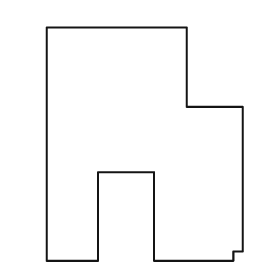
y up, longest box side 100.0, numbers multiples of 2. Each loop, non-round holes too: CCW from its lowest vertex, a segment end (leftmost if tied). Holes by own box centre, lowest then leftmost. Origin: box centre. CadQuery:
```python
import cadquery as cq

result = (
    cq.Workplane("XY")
    .moveTo(-42.0, -50.0)
    .lineTo(-20.0, -50.0)
    .lineTo(-20.0, -12.0)
    .lineTo(4.0, -12.0)
    .lineTo(4.0, -50.0)
    .lineTo(38.0, -50.0)
    .lineTo(38.0, -46.0)
    .lineTo(42.0, -46.0)
    .lineTo(42.0, 16.0)
    .lineTo(18.0, 16.0)
    .lineTo(18.0, 50.0)
    .lineTo(-42.0, 50.0)
    .close()
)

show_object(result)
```